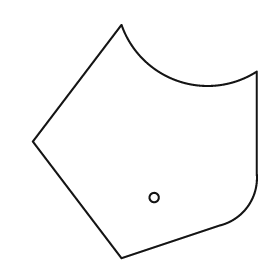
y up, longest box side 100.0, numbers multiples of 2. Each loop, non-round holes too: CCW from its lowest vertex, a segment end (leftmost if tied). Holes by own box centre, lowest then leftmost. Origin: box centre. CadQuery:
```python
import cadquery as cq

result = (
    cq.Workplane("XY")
    .moveTo(-10.0, -50.0)
    .lineTo(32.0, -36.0)
    .threePointArc((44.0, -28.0), (48.0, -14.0))
    .lineTo(48.0, 30.0)
    .threePointArc((14.0, 26.0), (-10.0, 50.0))
    .lineTo(-48.0, 0.0)
    .close()
    .moveTo(4.0, -24.0)
    .circle(2.0)
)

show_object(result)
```